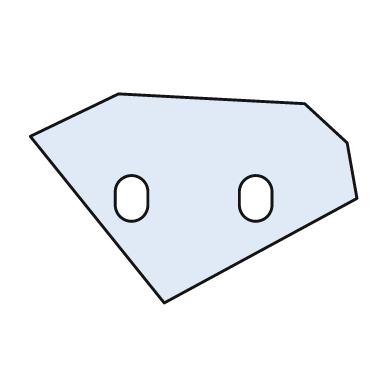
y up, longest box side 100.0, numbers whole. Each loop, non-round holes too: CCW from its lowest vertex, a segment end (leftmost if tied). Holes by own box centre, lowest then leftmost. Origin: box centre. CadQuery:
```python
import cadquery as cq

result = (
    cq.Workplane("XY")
    .moveTo(-9.0, -32.0)
    .lineTo(50.0, 0.0)
    .lineTo(47.0, 17.0)
    .lineTo(34.0, 29.0)
    .lineTo(-23.0, 32.0)
    .lineTo(-50.0, 19.0)
    .close()
    .moveTo(-24.0, -2.0)
    .threePointArc((-19.0, -7.0), (-14.0, -2.0))
    .lineTo(-14.0, 2.0)
    .threePointArc((-19.0, 7.0), (-24.0, 2.0))
    .close()
    .moveTo(14.0, -2.0)
    .threePointArc((19.0, -7.0), (24.0, -2.0))
    .lineTo(24.0, 2.0)
    .threePointArc((19.0, 7.0), (14.0, 2.0))
    .close()
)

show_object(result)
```